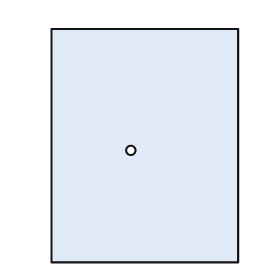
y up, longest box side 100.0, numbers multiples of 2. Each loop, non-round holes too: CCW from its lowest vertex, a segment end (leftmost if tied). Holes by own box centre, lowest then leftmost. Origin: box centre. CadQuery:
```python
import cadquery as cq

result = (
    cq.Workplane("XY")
    .moveTo(-40.0, -50.0)
    .lineTo(40.0, -50.0)
    .lineTo(40.0, 50.0)
    .lineTo(-40.0, 50.0)
    .close()
    .moveTo(-6.0, -2.0)
    .circle(2.0)
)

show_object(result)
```